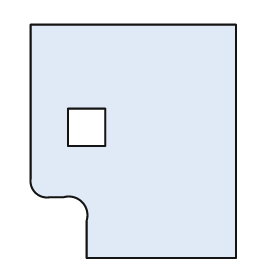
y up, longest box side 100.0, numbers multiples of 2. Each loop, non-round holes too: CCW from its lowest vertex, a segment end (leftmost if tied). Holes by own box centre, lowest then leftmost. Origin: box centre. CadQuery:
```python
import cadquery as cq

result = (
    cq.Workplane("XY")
    .moveTo(-20.0, -50.0)
    .lineTo(44.0, -50.0)
    .lineTo(44.0, 50.0)
    .lineTo(-44.0, 50.0)
    .lineTo(-44.0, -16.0)
    .threePointArc((-42.0, -22.0), (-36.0, -24.0))
    .lineTo(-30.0, -24.0)
    .threePointArc((-22.0, -26.0), (-20.0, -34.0))
    .close()
    .moveTo(-28.0, -2.0)
    .lineTo(-12.0, -2.0)
    .lineTo(-12.0, 14.0)
    .lineTo(-28.0, 14.0)
    .close()
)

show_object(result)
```